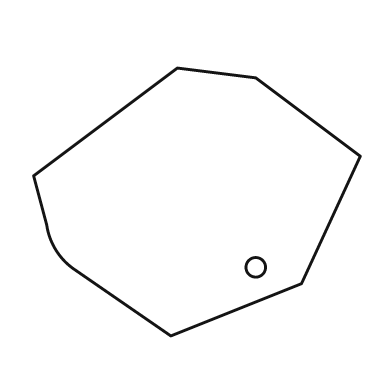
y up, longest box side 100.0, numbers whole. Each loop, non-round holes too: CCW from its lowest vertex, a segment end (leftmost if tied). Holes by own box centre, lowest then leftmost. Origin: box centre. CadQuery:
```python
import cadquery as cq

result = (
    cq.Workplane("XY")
    .moveTo(-8.0, -41.0)
    .lineTo(32.0, -25.0)
    .lineTo(50.0, 14.0)
    .lineTo(18.0, 38.0)
    .lineTo(-6.0, 41.0)
    .lineTo(-50.0, 8.0)
    .lineTo(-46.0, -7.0)
    .threePointArc((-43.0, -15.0), (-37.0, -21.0))
    .close()
    .moveTo(18.0, -20.0)
    .circle(3.0)
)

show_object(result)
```